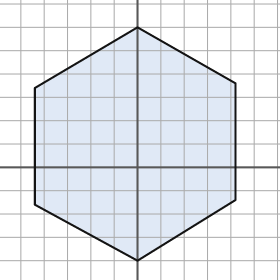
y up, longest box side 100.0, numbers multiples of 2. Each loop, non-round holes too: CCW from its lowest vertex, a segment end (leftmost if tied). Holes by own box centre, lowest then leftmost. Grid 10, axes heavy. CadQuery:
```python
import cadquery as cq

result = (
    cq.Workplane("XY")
    .moveTo(0.0, -40.0)
    .lineTo(42.0, -14.0)
    .lineTo(42.0, 36.0)
    .lineTo(0.0, 60.0)
    .lineTo(-44.0, 34.0)
    .lineTo(-44.0, -16.0)
    .close()
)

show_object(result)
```